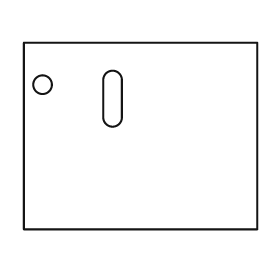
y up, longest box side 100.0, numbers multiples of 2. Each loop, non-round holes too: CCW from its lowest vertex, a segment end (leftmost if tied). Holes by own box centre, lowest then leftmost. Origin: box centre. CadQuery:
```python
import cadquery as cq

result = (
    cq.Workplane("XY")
    .moveTo(-50.0, -40.0)
    .lineTo(50.0, -40.0)
    .lineTo(50.0, 40.0)
    .lineTo(-50.0, 40.0)
    .close()
    .moveTo(-16.0, 8.0)
    .threePointArc((-12.0, 4.0), (-8.0, 8.0))
    .lineTo(-8.0, 24.0)
    .threePointArc((-12.0, 28.0), (-16.0, 24.0))
    .close()
    .moveTo(-42.0, 22.0)
    .circle(4.0)
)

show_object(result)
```